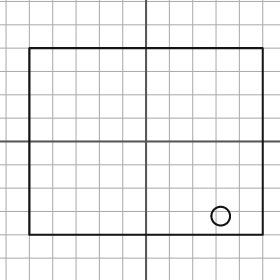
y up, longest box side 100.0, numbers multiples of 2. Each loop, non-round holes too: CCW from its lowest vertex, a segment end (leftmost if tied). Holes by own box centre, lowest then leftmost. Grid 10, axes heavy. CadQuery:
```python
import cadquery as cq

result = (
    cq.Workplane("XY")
    .moveTo(-50.0, -40.0)
    .lineTo(50.0, -40.0)
    .lineTo(50.0, 40.0)
    .lineTo(-50.0, 40.0)
    .close()
    .moveTo(32.0, -32.0)
    .circle(4.0)
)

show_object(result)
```